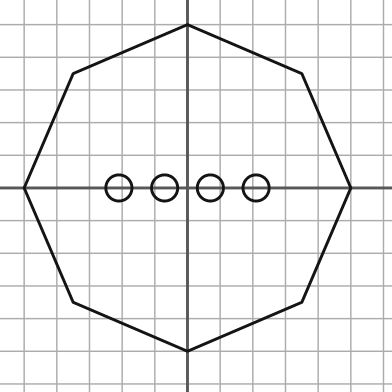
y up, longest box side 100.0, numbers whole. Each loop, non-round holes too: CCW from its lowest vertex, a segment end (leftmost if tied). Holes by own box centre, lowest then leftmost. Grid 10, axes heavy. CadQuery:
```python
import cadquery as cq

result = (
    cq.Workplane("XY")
    .moveTo(0.0, -50.0)
    .lineTo(35.0, -35.0)
    .lineTo(50.0, 0.0)
    .lineTo(35.0, 35.0)
    .lineTo(0.0, 50.0)
    .lineTo(-35.0, 35.0)
    .lineTo(-50.0, 0.0)
    .lineTo(-35.0, -35.0)
    .close()
    .moveTo(-21.0, 0.0)
    .circle(4.0)
    .moveTo(-7.0, 0.0)
    .circle(4.0)
    .moveTo(7.0, 0.0)
    .circle(4.0)
    .moveTo(21.0, 0.0)
    .circle(4.0)
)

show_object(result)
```